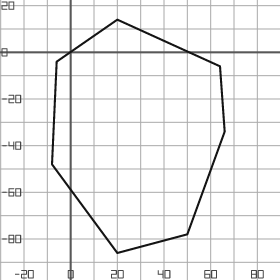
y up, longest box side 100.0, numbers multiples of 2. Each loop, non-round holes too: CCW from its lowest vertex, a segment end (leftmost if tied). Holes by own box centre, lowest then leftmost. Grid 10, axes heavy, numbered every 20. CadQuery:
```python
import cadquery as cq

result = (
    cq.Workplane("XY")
    .moveTo(20.0, -86.0)
    .lineTo(50.0, -78.0)
    .lineTo(66.0, -34.0)
    .lineTo(64.0, -6.0)
    .lineTo(20.0, 14.0)
    .lineTo(-6.0, -4.0)
    .lineTo(-8.0, -48.0)
    .close()
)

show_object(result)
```